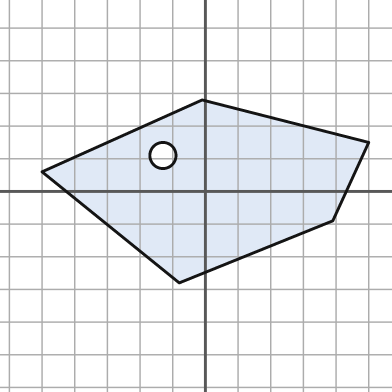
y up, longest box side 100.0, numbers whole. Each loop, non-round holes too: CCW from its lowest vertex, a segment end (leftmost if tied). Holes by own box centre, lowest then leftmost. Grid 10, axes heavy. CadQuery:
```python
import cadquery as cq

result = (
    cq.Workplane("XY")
    .moveTo(-8.0, -28.0)
    .lineTo(39.0, -9.0)
    .lineTo(50.0, 15.0)
    .lineTo(-1.0, 28.0)
    .lineTo(-50.0, 6.0)
    .close()
    .moveTo(-13.0, 11.0)
    .circle(4.0)
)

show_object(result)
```